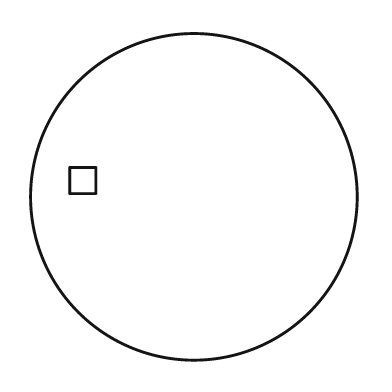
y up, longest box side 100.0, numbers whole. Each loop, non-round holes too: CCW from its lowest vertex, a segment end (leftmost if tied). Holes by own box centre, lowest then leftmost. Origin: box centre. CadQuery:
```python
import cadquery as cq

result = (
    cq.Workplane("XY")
    .moveTo(0.0, 0.0)
    .circle(50.0)
    .moveTo(-38.0, 1.0)
    .lineTo(-30.0, 1.0)
    .lineTo(-30.0, 9.0)
    .lineTo(-38.0, 9.0)
    .close()
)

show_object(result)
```